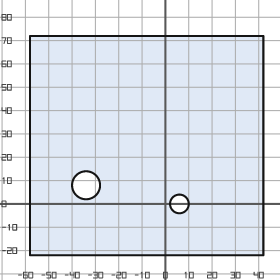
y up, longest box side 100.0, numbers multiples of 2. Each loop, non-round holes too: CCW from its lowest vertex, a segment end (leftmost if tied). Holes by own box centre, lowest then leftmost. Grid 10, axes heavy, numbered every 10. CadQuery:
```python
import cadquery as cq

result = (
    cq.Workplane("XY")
    .moveTo(-58.0, -22.0)
    .lineTo(42.0, -22.0)
    .lineTo(42.0, 72.0)
    .lineTo(-58.0, 72.0)
    .close()
    .moveTo(6.0, 0.0)
    .circle(4.0)
    .moveTo(-34.0, 8.0)
    .circle(6.0)
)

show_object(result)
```